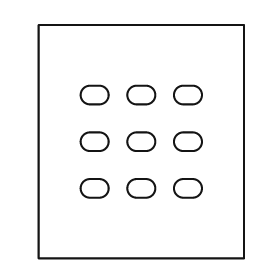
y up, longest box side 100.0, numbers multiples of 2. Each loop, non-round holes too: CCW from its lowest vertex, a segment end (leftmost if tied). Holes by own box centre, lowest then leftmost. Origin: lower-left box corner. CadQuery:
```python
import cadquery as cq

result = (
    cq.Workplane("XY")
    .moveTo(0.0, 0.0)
    .lineTo(88.0, 0.0)
    .lineTo(88.0, 100.0)
    .lineTo(0.0, 100.0)
    .close()
    .moveTo(22.0, 26.0)
    .lineTo(26.0, 26.0)
    .threePointArc((30.0, 30.0), (26.0, 34.0))
    .lineTo(22.0, 34.0)
    .threePointArc((18.0, 30.0), (22.0, 26.0))
    .close()
    .moveTo(42.0, 26.0)
    .lineTo(46.0, 26.0)
    .threePointArc((50.0, 30.0), (46.0, 34.0))
    .lineTo(42.0, 34.0)
    .threePointArc((38.0, 30.0), (42.0, 26.0))
    .close()
    .moveTo(62.0, 26.0)
    .lineTo(66.0, 26.0)
    .threePointArc((70.0, 30.0), (66.0, 34.0))
    .lineTo(62.0, 34.0)
    .threePointArc((58.0, 30.0), (62.0, 26.0))
    .close()
    .moveTo(22.0, 46.0)
    .lineTo(26.0, 46.0)
    .threePointArc((30.0, 50.0), (26.0, 54.0))
    .lineTo(22.0, 54.0)
    .threePointArc((18.0, 50.0), (22.0, 46.0))
    .close()
    .moveTo(42.0, 46.0)
    .lineTo(46.0, 46.0)
    .threePointArc((50.0, 50.0), (46.0, 54.0))
    .lineTo(42.0, 54.0)
    .threePointArc((38.0, 50.0), (42.0, 46.0))
    .close()
    .moveTo(62.0, 46.0)
    .lineTo(66.0, 46.0)
    .threePointArc((70.0, 50.0), (66.0, 54.0))
    .lineTo(62.0, 54.0)
    .threePointArc((58.0, 50.0), (62.0, 46.0))
    .close()
    .moveTo(22.0, 66.0)
    .lineTo(26.0, 66.0)
    .threePointArc((30.0, 70.0), (26.0, 74.0))
    .lineTo(22.0, 74.0)
    .threePointArc((18.0, 70.0), (22.0, 66.0))
    .close()
    .moveTo(42.0, 66.0)
    .lineTo(46.0, 66.0)
    .threePointArc((50.0, 70.0), (46.0, 74.0))
    .lineTo(42.0, 74.0)
    .threePointArc((38.0, 70.0), (42.0, 66.0))
    .close()
    .moveTo(62.0, 66.0)
    .lineTo(66.0, 66.0)
    .threePointArc((70.0, 70.0), (66.0, 74.0))
    .lineTo(62.0, 74.0)
    .threePointArc((58.0, 70.0), (62.0, 66.0))
    .close()
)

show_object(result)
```